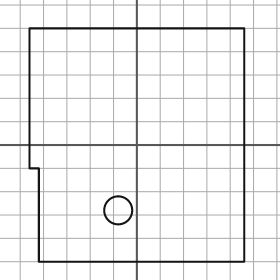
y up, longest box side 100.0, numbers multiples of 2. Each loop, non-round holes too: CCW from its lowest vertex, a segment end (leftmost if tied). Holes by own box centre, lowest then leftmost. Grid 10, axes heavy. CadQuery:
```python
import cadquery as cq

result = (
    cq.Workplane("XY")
    .moveTo(-42.0, -50.0)
    .lineTo(46.0, -50.0)
    .lineTo(46.0, 50.0)
    .lineTo(-46.0, 50.0)
    .lineTo(-46.0, -10.0)
    .lineTo(-42.0, -10.0)
    .close()
    .moveTo(-8.0, -28.0)
    .circle(6.0)
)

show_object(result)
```